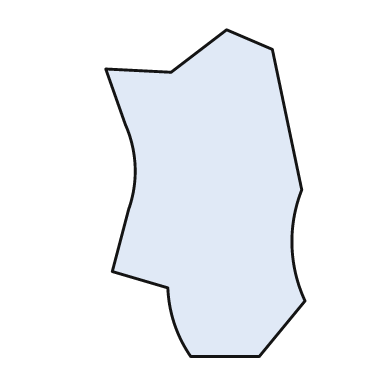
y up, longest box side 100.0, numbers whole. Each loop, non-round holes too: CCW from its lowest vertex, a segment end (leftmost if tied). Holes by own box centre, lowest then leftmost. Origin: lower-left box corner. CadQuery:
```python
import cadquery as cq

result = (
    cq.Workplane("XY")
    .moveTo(26.0, 0.0)
    .lineTo(47.0, 0.0)
    .lineTo(61.0, 17.0)
    .threePointArc((57.0, 34.0), (60.0, 51.0))
    .lineTo(51.0, 94.0)
    .lineTo(37.0, 100.0)
    .lineTo(20.0, 87.0)
    .lineTo(0.0, 88.0)
    .lineTo(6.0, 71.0)
    .threePointArc((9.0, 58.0), (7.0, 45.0))
    .lineTo(2.0, 26.0)
    .lineTo(19.0, 21.0)
    .threePointArc((21.0, 10.0), (26.0, 0.0))
    .close()
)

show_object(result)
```